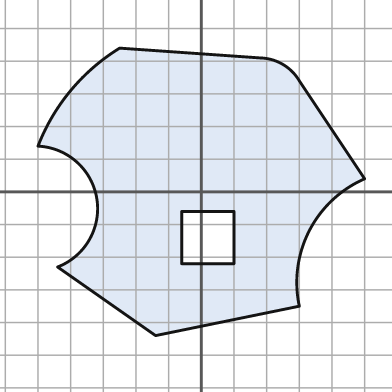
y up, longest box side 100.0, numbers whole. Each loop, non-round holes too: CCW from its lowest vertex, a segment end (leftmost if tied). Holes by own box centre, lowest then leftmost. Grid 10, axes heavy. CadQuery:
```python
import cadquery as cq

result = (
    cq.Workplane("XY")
    .moveTo(-14.0, -44.0)
    .lineTo(30.0, -35.0)
    .threePointArc((33.0, -12.0), (50.0, 4.0))
    .lineTo(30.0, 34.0)
    .threePointArc((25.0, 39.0), (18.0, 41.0))
    .lineTo(-25.0, 44.0)
    .threePointArc((-40.0, 31.0), (-50.0, 14.0))
    .threePointArc((-32.0, -2.0), (-44.0, -23.0))
    .close()
    .moveTo(-6.0, -22.0)
    .lineTo(10.0, -22.0)
    .lineTo(10.0, -6.0)
    .lineTo(-6.0, -6.0)
    .close()
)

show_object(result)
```